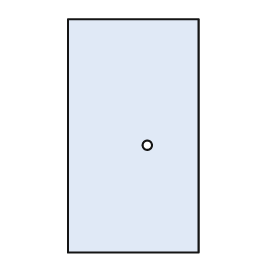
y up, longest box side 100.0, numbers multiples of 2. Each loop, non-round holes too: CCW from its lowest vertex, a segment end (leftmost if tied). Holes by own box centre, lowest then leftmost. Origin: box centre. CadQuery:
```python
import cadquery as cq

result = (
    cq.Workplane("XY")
    .moveTo(-28.0, -50.0)
    .lineTo(28.0, -50.0)
    .lineTo(28.0, 50.0)
    .lineTo(-28.0, 50.0)
    .close()
    .moveTo(6.0, -4.0)
    .circle(2.0)
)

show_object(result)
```